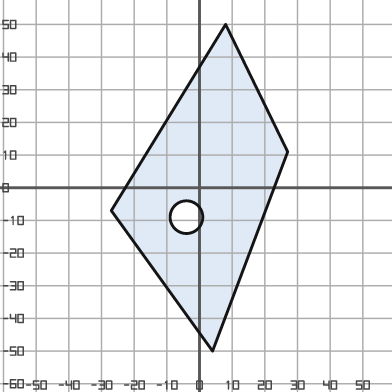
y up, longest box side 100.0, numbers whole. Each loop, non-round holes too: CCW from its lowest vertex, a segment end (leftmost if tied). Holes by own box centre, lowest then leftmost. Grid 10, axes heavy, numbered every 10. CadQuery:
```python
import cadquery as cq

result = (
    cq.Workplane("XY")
    .moveTo(4.0, -50.0)
    .lineTo(27.0, 11.0)
    .lineTo(8.0, 50.0)
    .lineTo(-27.0, -7.0)
    .close()
    .moveTo(-4.0, -9.0)
    .circle(5.0)
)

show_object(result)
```